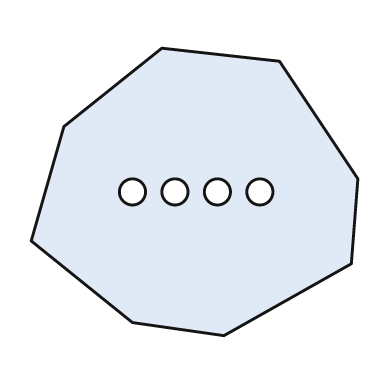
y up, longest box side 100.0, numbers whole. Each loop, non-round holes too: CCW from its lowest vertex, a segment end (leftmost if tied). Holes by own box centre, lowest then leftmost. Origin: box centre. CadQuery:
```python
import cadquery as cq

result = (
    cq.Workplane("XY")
    .moveTo(9.0, -44.0)
    .lineTo(48.0, -22.0)
    .lineTo(50.0, 4.0)
    .lineTo(26.0, 40.0)
    .lineTo(-10.0, 44.0)
    .lineTo(-40.0, 20.0)
    .lineTo(-50.0, -15.0)
    .lineTo(-19.0, -40.0)
    .close()
    .moveTo(-19.0, 0.0)
    .circle(4.0)
    .moveTo(-6.0, 0.0)
    .circle(4.0)
    .moveTo(7.0, 0.0)
    .circle(4.0)
    .moveTo(20.0, 0.0)
    .circle(4.0)
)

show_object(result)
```